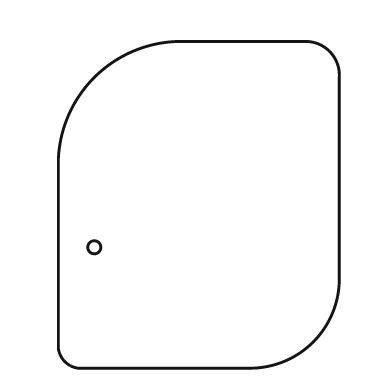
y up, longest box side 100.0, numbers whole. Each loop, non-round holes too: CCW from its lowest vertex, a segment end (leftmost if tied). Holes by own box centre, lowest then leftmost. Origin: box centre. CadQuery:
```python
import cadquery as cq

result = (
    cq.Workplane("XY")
    .moveTo(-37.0, -50.0)
    .lineTo(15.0, -50.0)
    .threePointArc((35.0, -42.0), (43.0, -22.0))
    .lineTo(43.0, 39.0)
    .threePointArc((40.0, 47.0), (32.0, 50.0))
    .lineTo(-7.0, 50.0)
    .threePointArc((-32.0, 39.0), (-43.0, 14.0))
    .lineTo(-43.0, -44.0)
    .threePointArc((-41.0, -48.0), (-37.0, -50.0))
    .close()
    .moveTo(-32.0, -13.0)
    .circle(2.0)
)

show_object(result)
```